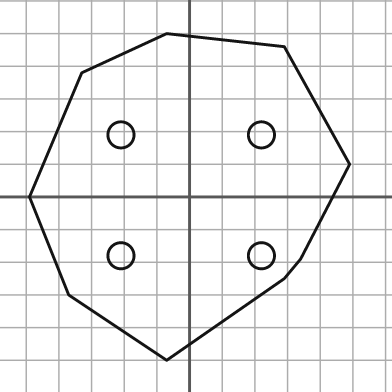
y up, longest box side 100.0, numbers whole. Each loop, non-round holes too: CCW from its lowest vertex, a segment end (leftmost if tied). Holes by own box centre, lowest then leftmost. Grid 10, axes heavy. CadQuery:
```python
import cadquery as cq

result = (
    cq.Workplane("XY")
    .moveTo(-7.0, -50.0)
    .lineTo(29.0, -25.0)
    .lineTo(34.0, -19.0)
    .lineTo(49.0, 10.0)
    .lineTo(29.0, 46.0)
    .lineTo(-7.0, 50.0)
    .lineTo(-33.0, 38.0)
    .lineTo(-49.0, 0.0)
    .lineTo(-37.0, -30.0)
    .close()
    .moveTo(-21.0, -18.0)
    .circle(4.0)
    .moveTo(22.0, -18.0)
    .circle(4.0)
    .moveTo(-21.0, 19.0)
    .circle(4.0)
    .moveTo(22.0, 19.0)
    .circle(4.0)
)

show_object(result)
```